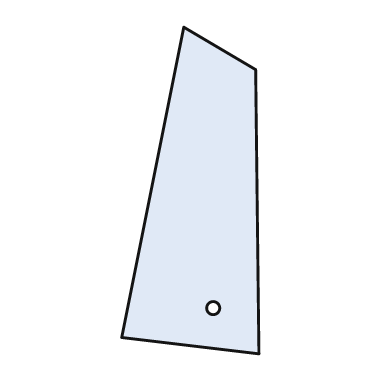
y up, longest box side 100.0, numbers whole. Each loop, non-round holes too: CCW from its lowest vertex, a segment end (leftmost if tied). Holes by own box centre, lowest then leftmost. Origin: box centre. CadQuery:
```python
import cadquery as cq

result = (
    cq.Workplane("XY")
    .moveTo(21.0, -50.0)
    .lineTo(20.0, 37.0)
    .lineTo(-2.0, 50.0)
    .lineTo(-21.0, -45.0)
    .close()
    .moveTo(7.0, -36.0)
    .circle(2.0)
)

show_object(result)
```